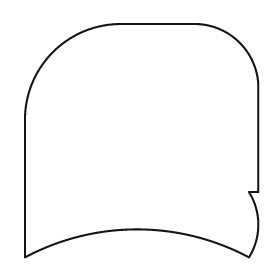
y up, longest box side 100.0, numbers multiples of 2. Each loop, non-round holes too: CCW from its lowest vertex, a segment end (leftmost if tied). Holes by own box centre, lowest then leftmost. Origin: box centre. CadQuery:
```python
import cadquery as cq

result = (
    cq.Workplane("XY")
    .moveTo(-50.0, -50.0)
    .threePointArc((-2.0, -38.0), (46.0, -50.0))
    .threePointArc((50.0, -36.0), (46.0, -22.0))
    .lineTo(50.0, -22.0)
    .lineTo(50.0, 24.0)
    .threePointArc((42.0, 42.0), (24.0, 50.0))
    .lineTo(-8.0, 50.0)
    .threePointArc((-38.0, 38.0), (-50.0, 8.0))
    .close()
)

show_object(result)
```